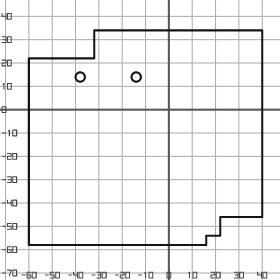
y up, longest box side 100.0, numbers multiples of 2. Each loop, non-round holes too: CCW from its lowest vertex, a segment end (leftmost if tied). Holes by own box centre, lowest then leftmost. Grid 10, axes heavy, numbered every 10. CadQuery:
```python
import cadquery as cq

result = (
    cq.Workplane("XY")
    .moveTo(-60.0, -58.0)
    .lineTo(16.0, -58.0)
    .lineTo(16.0, -54.0)
    .lineTo(22.0, -54.0)
    .lineTo(22.0, -46.0)
    .lineTo(40.0, -46.0)
    .lineTo(40.0, 34.0)
    .lineTo(-32.0, 34.0)
    .lineTo(-32.0, 22.0)
    .lineTo(-60.0, 22.0)
    .close()
    .moveTo(-38.0, 14.0)
    .circle(2.0)
    .moveTo(-14.0, 14.0)
    .circle(2.0)
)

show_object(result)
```